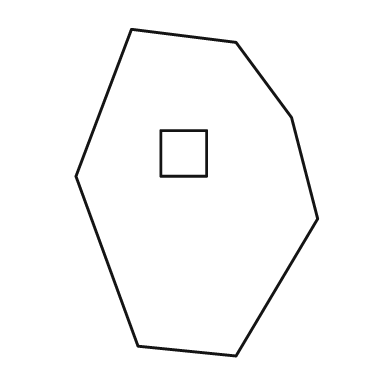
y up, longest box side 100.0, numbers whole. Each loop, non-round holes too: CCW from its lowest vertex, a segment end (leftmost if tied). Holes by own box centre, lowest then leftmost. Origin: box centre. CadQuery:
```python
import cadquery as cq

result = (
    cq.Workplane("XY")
    .moveTo(12.0, -50.0)
    .lineTo(37.0, -8.0)
    .lineTo(29.0, 23.0)
    .lineTo(12.0, 46.0)
    .lineTo(-20.0, 50.0)
    .lineTo(-37.0, 5.0)
    .lineTo(-18.0, -47.0)
    .close()
    .moveTo(-11.0, 5.0)
    .lineTo(3.0, 5.0)
    .lineTo(3.0, 19.0)
    .lineTo(-11.0, 19.0)
    .close()
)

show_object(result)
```